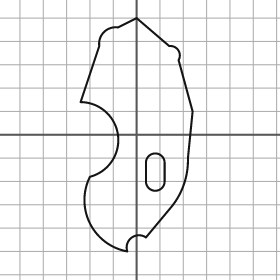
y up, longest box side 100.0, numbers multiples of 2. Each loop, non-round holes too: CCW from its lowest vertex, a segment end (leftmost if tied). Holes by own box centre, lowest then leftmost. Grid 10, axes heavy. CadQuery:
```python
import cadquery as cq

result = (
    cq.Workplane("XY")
    .moveTo(-4.0, -50.0)
    .threePointArc((-2.0, -44.0), (4.0, -44.0))
    .lineTo(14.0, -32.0)
    .threePointArc((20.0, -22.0), (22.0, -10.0))
    .lineTo(24.0, 10.0)
    .lineTo(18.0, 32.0)
    .threePointArc((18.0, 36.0), (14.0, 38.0))
    .lineTo(0.0, 50.0)
    .lineTo(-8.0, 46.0)
    .threePointArc((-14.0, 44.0), (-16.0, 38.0))
    .lineTo(-24.0, 14.0)
    .threePointArc((-8.0, 0.0), (-20.0, -18.0))
    .threePointArc((-20.0, -38.0), (-4.0, -50.0))
    .close()
    .moveTo(4.0, -20.0)
    .threePointArc((8.0, -24.0), (12.0, -20.0))
    .lineTo(12.0, -12.0)
    .threePointArc((8.0, -8.0), (4.0, -12.0))
    .close()
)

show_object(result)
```